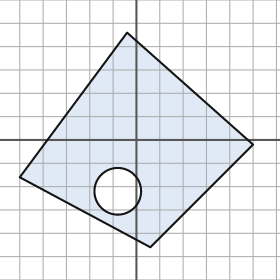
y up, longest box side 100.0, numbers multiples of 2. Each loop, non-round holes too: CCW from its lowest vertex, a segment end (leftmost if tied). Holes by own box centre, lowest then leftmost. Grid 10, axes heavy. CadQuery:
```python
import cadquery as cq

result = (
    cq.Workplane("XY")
    .moveTo(6.0, -46.0)
    .lineTo(50.0, -2.0)
    .lineTo(-4.0, 46.0)
    .lineTo(-50.0, -16.0)
    .close()
    .moveTo(-8.0, -22.0)
    .circle(10.0)
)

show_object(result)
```